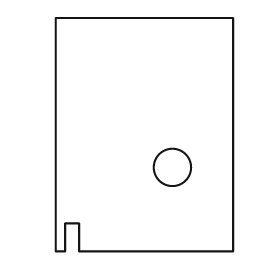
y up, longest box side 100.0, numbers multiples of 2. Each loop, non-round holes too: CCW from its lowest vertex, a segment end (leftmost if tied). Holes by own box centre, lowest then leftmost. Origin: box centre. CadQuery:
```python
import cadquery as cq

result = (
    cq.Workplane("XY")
    .moveTo(-38.0, -50.0)
    .lineTo(-34.0, -50.0)
    .lineTo(-34.0, -38.0)
    .lineTo(-28.0, -38.0)
    .lineTo(-28.0, -50.0)
    .lineTo(38.0, -50.0)
    .lineTo(38.0, 50.0)
    .lineTo(-38.0, 50.0)
    .close()
    .moveTo(12.0, -14.0)
    .circle(8.0)
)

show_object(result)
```